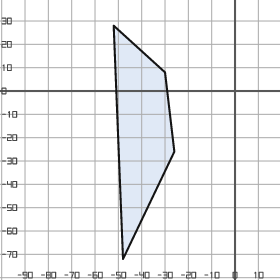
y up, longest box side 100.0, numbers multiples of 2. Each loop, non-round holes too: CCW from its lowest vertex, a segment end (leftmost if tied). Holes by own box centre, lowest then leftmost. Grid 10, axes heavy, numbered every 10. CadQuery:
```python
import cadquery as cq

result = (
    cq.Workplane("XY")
    .moveTo(-48.0, -72.0)
    .lineTo(-26.0, -26.0)
    .lineTo(-30.0, 8.0)
    .lineTo(-52.0, 28.0)
    .close()
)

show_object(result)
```